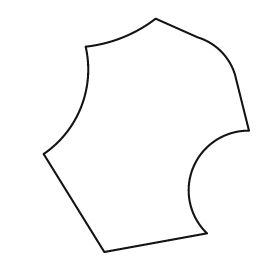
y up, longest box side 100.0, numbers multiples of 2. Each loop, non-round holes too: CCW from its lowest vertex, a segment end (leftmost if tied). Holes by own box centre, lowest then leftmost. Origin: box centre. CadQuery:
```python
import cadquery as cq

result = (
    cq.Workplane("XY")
    .moveTo(-18.0, -50.0)
    .lineTo(26.0, -42.0)
    .threePointArc((20.0, -14.0), (44.0, 2.0))
    .lineTo(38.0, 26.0)
    .threePointArc((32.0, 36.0), (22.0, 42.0))
    .lineTo(4.0, 50.0)
    .threePointArc((-10.0, 42.0), (-26.0, 38.0))
    .threePointArc((-28.0, 12.0), (-44.0, -8.0))
    .close()
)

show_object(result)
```